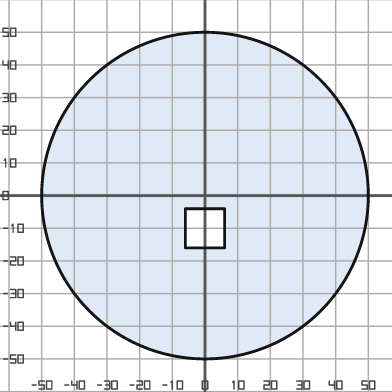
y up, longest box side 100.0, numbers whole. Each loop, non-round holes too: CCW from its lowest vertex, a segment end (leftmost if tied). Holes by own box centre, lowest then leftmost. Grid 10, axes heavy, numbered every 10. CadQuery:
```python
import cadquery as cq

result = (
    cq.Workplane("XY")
    .moveTo(0.0, 0.0)
    .circle(50.0)
    .moveTo(-6.0, -16.0)
    .lineTo(6.0, -16.0)
    .lineTo(6.0, -4.0)
    .lineTo(-6.0, -4.0)
    .close()
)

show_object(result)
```